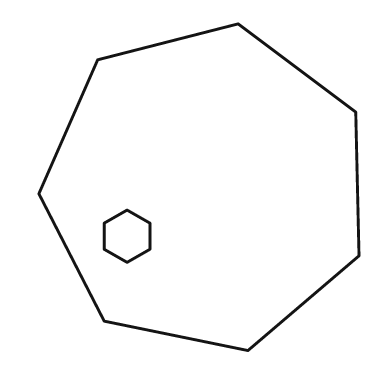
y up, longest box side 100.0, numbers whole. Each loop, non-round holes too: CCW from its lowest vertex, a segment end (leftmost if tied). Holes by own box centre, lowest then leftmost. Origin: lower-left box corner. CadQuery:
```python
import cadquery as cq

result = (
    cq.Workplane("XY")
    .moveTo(64.0, 0.0)
    .lineTo(98.0, 29.0)
    .lineTo(97.0, 73.0)
    .lineTo(61.0, 100.0)
    .lineTo(18.0, 89.0)
    .lineTo(0.0, 48.0)
    .lineTo(20.0, 9.0)
    .close()
    .moveTo(27.0, 27.0)
    .lineTo(34.0, 31.0)
    .lineTo(34.0, 39.0)
    .lineTo(27.0, 43.0)
    .lineTo(20.0, 39.0)
    .lineTo(20.0, 31.0)
    .close()
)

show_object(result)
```